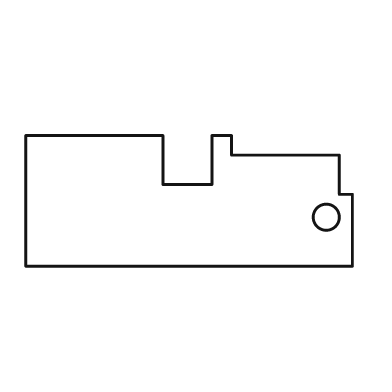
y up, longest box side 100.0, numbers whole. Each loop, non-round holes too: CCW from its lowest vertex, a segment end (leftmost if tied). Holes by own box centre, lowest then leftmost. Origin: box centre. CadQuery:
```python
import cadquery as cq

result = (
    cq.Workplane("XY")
    .moveTo(-50.0, -20.0)
    .lineTo(50.0, -20.0)
    .lineTo(50.0, 2.0)
    .lineTo(46.0, 2.0)
    .lineTo(46.0, 14.0)
    .lineTo(13.0, 14.0)
    .lineTo(13.0, 20.0)
    .lineTo(7.0, 20.0)
    .lineTo(7.0, 5.0)
    .lineTo(-8.0, 5.0)
    .lineTo(-8.0, 20.0)
    .lineTo(-50.0, 20.0)
    .close()
    .moveTo(42.0, -5.0)
    .circle(4.0)
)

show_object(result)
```